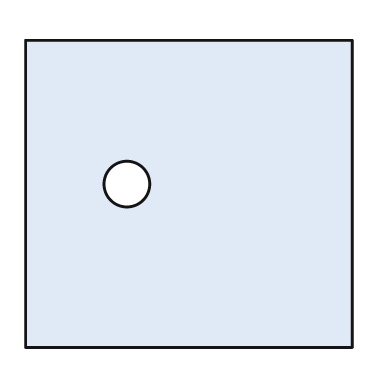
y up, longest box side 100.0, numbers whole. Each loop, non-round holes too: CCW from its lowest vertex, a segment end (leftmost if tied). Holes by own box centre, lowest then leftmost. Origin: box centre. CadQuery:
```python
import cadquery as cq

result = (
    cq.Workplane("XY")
    .moveTo(-50.0, -47.0)
    .lineTo(50.0, -47.0)
    .lineTo(50.0, 47.0)
    .lineTo(-50.0, 47.0)
    .close()
    .moveTo(-19.0, 3.0)
    .circle(7.0)
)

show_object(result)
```